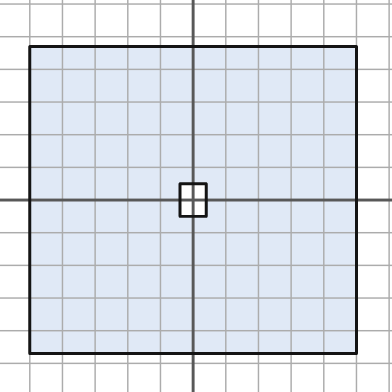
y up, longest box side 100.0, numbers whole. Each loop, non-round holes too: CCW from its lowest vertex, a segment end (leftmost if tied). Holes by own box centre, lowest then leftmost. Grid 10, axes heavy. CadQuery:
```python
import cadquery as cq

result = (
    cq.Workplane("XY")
    .moveTo(-50.0, -47.0)
    .lineTo(50.0, -47.0)
    .lineTo(50.0, 47.0)
    .lineTo(-50.0, 47.0)
    .close()
    .moveTo(-4.0, -5.0)
    .lineTo(4.0, -5.0)
    .lineTo(4.0, 5.0)
    .lineTo(-4.0, 5.0)
    .close()
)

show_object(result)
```